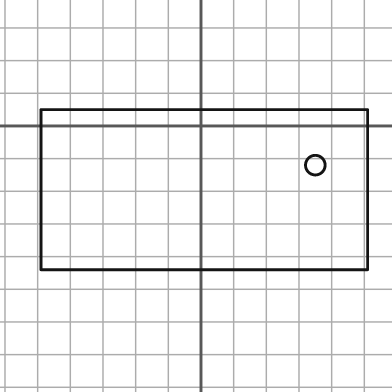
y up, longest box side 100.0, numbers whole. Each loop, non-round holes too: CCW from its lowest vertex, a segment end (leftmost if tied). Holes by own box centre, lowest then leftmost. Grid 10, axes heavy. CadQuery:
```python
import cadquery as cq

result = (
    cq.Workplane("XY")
    .moveTo(-49.0, -44.0)
    .lineTo(51.0, -44.0)
    .lineTo(51.0, 5.0)
    .lineTo(-49.0, 5.0)
    .close()
    .moveTo(35.0, -12.0)
    .circle(3.0)
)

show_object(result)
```